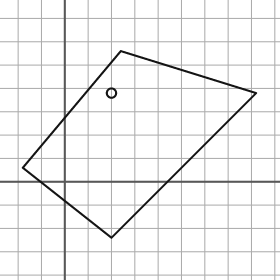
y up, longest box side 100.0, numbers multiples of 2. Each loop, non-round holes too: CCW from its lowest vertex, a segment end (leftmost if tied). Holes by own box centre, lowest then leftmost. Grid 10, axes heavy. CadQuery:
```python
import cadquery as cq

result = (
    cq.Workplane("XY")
    .moveTo(20.0, -24.0)
    .lineTo(82.0, 38.0)
    .lineTo(24.0, 56.0)
    .lineTo(-18.0, 6.0)
    .close()
    .moveTo(20.0, 38.0)
    .circle(2.0)
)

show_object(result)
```